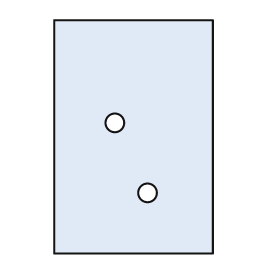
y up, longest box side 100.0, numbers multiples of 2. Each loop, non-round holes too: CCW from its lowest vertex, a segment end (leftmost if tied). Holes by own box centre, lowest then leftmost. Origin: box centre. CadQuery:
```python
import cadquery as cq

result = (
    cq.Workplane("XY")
    .moveTo(-34.0, -50.0)
    .lineTo(34.0, -50.0)
    .lineTo(34.0, 50.0)
    .lineTo(-34.0, 50.0)
    .close()
    .moveTo(6.0, -24.0)
    .circle(4.0)
    .moveTo(-8.0, 6.0)
    .circle(4.0)
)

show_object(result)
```